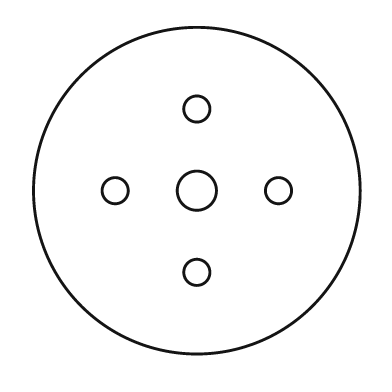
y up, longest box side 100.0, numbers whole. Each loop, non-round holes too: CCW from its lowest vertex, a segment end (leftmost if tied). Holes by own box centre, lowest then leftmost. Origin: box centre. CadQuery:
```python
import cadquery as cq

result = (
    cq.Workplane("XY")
    .moveTo(0.0, 0.0)
    .circle(50.0)
    .moveTo(0.0, -25.0)
    .circle(4.0)
    .moveTo(-25.0, 0.0)
    .circle(4.0)
    .moveTo(0.0, 0.0)
    .circle(6.0)
    .moveTo(25.0, 0.0)
    .circle(4.0)
    .moveTo(0.0, 25.0)
    .circle(4.0)
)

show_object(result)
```